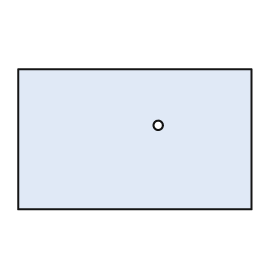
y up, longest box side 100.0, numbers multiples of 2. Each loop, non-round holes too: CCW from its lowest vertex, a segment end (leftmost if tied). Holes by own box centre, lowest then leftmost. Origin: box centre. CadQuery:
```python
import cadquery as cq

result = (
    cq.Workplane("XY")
    .moveTo(-50.0, -30.0)
    .lineTo(50.0, -30.0)
    .lineTo(50.0, 30.0)
    .lineTo(-50.0, 30.0)
    .close()
    .moveTo(10.0, 6.0)
    .circle(2.0)
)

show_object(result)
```